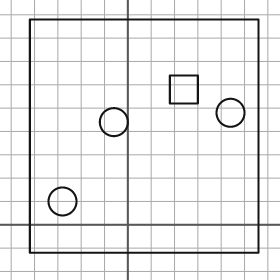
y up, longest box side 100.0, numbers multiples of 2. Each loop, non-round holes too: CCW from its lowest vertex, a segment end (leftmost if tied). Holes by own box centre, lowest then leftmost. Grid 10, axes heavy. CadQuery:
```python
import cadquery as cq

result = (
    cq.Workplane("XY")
    .moveTo(-42.0, -12.0)
    .lineTo(56.0, -12.0)
    .lineTo(56.0, 88.0)
    .lineTo(-42.0, 88.0)
    .close()
    .moveTo(-28.0, 10.0)
    .circle(6.0)
    .moveTo(-6.0, 44.0)
    .circle(6.0)
    .moveTo(44.0, 48.0)
    .circle(6.0)
    .moveTo(18.0, 52.0)
    .lineTo(30.0, 52.0)
    .lineTo(30.0, 64.0)
    .lineTo(18.0, 64.0)
    .close()
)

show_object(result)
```